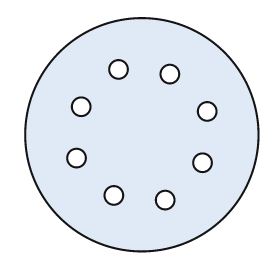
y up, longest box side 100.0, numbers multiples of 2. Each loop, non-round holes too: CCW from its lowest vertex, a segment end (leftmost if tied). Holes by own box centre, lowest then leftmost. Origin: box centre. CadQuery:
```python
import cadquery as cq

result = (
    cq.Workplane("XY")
    .moveTo(0.0, 0.0)
    .circle(50.0)
    .moveTo(10.0, -28.0)
    .circle(4.0)
    .moveTo(-12.0, -26.0)
    .circle(4.0)
    .moveTo(26.0, -12.0)
    .circle(4.0)
    .moveTo(-28.0, -10.0)
    .circle(4.0)
    .moveTo(28.0, 10.0)
    .circle(4.0)
    .moveTo(-26.0, 12.0)
    .circle(4.0)
    .moveTo(12.0, 26.0)
    .circle(4.0)
    .moveTo(-10.0, 28.0)
    .circle(4.0)
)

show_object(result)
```